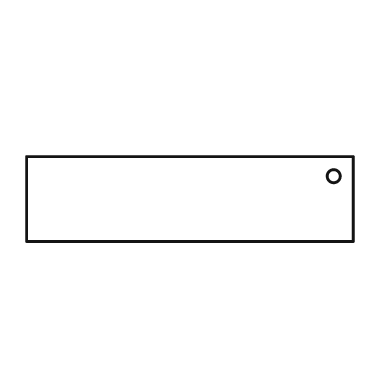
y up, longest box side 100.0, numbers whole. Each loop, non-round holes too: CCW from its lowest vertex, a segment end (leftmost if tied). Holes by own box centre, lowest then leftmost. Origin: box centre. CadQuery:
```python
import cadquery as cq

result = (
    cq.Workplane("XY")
    .moveTo(-50.0, -13.0)
    .lineTo(50.0, -13.0)
    .lineTo(50.0, 13.0)
    .lineTo(-50.0, 13.0)
    .close()
    .moveTo(44.0, 7.0)
    .circle(2.0)
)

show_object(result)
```